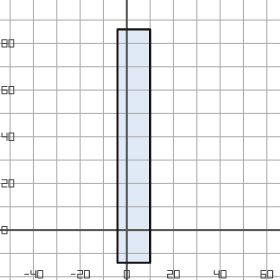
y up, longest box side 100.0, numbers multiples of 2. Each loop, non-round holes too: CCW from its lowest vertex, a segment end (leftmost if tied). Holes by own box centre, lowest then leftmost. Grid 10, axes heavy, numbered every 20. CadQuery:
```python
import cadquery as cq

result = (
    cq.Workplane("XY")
    .moveTo(-4.0, -14.0)
    .lineTo(10.0, -14.0)
    .lineTo(10.0, 86.0)
    .lineTo(-4.0, 86.0)
    .close()
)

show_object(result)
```